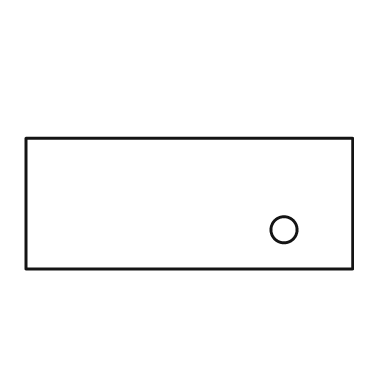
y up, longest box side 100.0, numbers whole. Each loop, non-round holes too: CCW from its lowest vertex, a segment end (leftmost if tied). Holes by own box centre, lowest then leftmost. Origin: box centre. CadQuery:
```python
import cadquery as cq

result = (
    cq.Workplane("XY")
    .moveTo(-50.0, -20.0)
    .lineTo(50.0, -20.0)
    .lineTo(50.0, 20.0)
    .lineTo(-50.0, 20.0)
    .close()
    .moveTo(29.0, -8.0)
    .circle(4.0)
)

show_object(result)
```